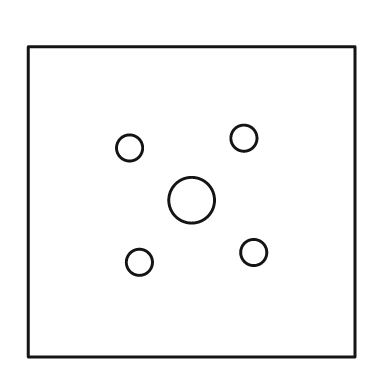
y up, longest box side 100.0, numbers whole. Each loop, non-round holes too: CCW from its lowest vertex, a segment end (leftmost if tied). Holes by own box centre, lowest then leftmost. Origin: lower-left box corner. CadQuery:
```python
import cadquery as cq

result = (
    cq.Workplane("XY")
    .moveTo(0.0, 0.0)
    .lineTo(100.0, 0.0)
    .lineTo(100.0, 95.0)
    .lineTo(0.0, 95.0)
    .close()
    .moveTo(34.0, 29.0)
    .circle(4.0)
    .moveTo(69.0, 32.0)
    .circle(4.0)
    .moveTo(50.0, 48.0)
    .circle(7.0)
    .moveTo(31.0, 64.0)
    .circle(4.0)
    .moveTo(66.0, 67.0)
    .circle(4.0)
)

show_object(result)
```